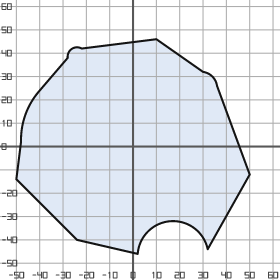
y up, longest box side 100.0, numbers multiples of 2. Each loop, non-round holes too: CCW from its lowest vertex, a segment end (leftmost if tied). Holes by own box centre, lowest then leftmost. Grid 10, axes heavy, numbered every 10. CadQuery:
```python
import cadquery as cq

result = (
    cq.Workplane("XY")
    .moveTo(2.0, -46.0)
    .threePointArc((16.0, -32.0), (32.0, -44.0))
    .lineTo(50.0, -12.0)
    .lineTo(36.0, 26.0)
    .threePointArc((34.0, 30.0), (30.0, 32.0))
    .lineTo(10.0, 46.0)
    .lineTo(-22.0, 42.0)
    .threePointArc((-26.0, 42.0), (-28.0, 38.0))
    .lineTo(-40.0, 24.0)
    .threePointArc((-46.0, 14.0), (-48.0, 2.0))
    .lineTo(-50.0, -14.0)
    .lineTo(-24.0, -40.0)
    .close()
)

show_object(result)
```